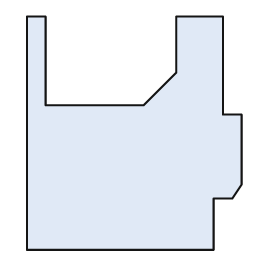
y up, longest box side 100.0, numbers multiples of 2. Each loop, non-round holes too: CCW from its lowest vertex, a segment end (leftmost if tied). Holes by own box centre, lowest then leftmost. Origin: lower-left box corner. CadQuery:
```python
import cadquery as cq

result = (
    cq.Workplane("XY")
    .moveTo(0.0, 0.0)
    .lineTo(80.0, 0.0)
    .lineTo(80.0, 22.0)
    .lineTo(88.0, 22.0)
    .lineTo(92.0, 28.0)
    .lineTo(92.0, 58.0)
    .lineTo(84.0, 58.0)
    .lineTo(84.0, 100.0)
    .lineTo(64.0, 100.0)
    .lineTo(64.0, 76.0)
    .lineTo(50.0, 62.0)
    .lineTo(8.0, 62.0)
    .lineTo(8.0, 100.0)
    .lineTo(0.0, 100.0)
    .close()
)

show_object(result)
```